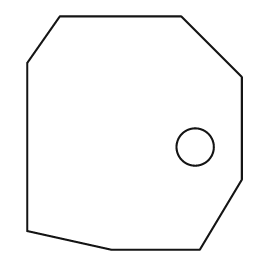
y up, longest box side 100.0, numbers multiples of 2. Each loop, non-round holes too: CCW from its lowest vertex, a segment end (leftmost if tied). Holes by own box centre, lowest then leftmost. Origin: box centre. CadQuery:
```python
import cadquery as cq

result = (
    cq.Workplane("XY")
    .moveTo(-10.0, -50.0)
    .lineTo(28.0, -50.0)
    .lineTo(46.0, -20.0)
    .lineTo(46.0, 24.0)
    .lineTo(20.0, 50.0)
    .lineTo(-32.0, 50.0)
    .lineTo(-46.0, 30.0)
    .lineTo(-46.0, -42.0)
    .close()
    .moveTo(26.0, -6.0)
    .circle(8.0)
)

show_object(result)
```